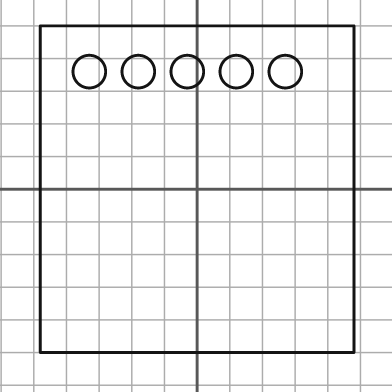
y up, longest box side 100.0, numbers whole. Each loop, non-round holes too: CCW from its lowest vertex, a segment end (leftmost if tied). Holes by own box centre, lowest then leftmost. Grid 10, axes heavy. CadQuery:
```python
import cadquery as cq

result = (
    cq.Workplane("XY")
    .moveTo(-48.0, -50.0)
    .lineTo(48.0, -50.0)
    .lineTo(48.0, 50.0)
    .lineTo(-48.0, 50.0)
    .close()
    .moveTo(-33.0, 36.0)
    .circle(5.0)
    .moveTo(-18.0, 36.0)
    .circle(5.0)
    .moveTo(-3.0, 36.0)
    .circle(5.0)
    .moveTo(12.0, 36.0)
    .circle(5.0)
    .moveTo(27.0, 36.0)
    .circle(5.0)
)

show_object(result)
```